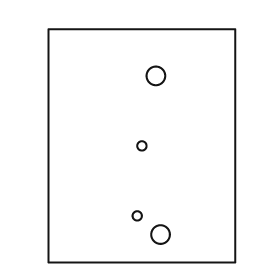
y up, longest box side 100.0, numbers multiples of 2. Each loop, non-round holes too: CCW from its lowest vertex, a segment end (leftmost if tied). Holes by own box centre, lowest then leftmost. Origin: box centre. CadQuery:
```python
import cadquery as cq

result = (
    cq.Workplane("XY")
    .moveTo(-40.0, -50.0)
    .lineTo(40.0, -50.0)
    .lineTo(40.0, 50.0)
    .lineTo(-40.0, 50.0)
    .close()
    .moveTo(8.0, -38.0)
    .circle(4.0)
    .moveTo(-2.0, -30.0)
    .circle(2.0)
    .moveTo(0.0, 0.0)
    .circle(2.0)
    .moveTo(6.0, 30.0)
    .circle(4.0)
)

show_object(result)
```